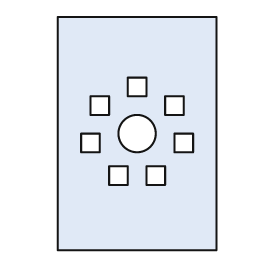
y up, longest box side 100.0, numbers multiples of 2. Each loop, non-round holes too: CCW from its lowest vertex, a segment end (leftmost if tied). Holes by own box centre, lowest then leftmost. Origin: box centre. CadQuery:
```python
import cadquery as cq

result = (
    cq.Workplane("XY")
    .moveTo(-34.0, -50.0)
    .lineTo(34.0, -50.0)
    .lineTo(34.0, 50.0)
    .lineTo(-34.0, 50.0)
    .close()
    .moveTo(-12.0, -22.0)
    .lineTo(-4.0, -22.0)
    .lineTo(-4.0, -14.0)
    .lineTo(-12.0, -14.0)
    .close()
    .moveTo(4.0, -22.0)
    .lineTo(12.0, -22.0)
    .lineTo(12.0, -14.0)
    .lineTo(4.0, -14.0)
    .close()
    .moveTo(-24.0, -8.0)
    .lineTo(-16.0, -8.0)
    .lineTo(-16.0, 0.0)
    .lineTo(-24.0, 0.0)
    .close()
    .moveTo(16.0, -8.0)
    .lineTo(24.0, -8.0)
    .lineTo(24.0, 0.0)
    .lineTo(16.0, 0.0)
    .close()
    .moveTo(0.0, 0.0)
    .circle(8.0)
    .moveTo(-20.0, 8.0)
    .lineTo(-12.0, 8.0)
    .lineTo(-12.0, 16.0)
    .lineTo(-20.0, 16.0)
    .close()
    .moveTo(12.0, 8.0)
    .lineTo(20.0, 8.0)
    .lineTo(20.0, 16.0)
    .lineTo(12.0, 16.0)
    .close()
    .moveTo(-4.0, 16.0)
    .lineTo(4.0, 16.0)
    .lineTo(4.0, 24.0)
    .lineTo(-4.0, 24.0)
    .close()
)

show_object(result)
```